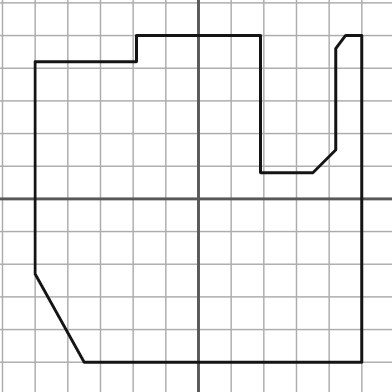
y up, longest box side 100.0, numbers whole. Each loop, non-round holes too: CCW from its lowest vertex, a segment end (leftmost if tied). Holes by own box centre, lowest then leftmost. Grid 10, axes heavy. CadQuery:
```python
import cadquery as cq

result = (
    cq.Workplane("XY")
    .moveTo(-35.0, -50.0)
    .lineTo(50.0, -50.0)
    .lineTo(50.0, 50.0)
    .lineTo(45.0, 50.0)
    .lineTo(42.0, 46.0)
    .lineTo(42.0, 15.0)
    .lineTo(35.0, 8.0)
    .lineTo(19.0, 8.0)
    .lineTo(19.0, 50.0)
    .lineTo(-19.0, 50.0)
    .lineTo(-19.0, 42.0)
    .lineTo(-50.0, 42.0)
    .lineTo(-50.0, -23.0)
    .close()
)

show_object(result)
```